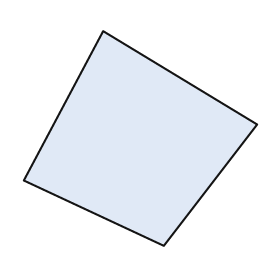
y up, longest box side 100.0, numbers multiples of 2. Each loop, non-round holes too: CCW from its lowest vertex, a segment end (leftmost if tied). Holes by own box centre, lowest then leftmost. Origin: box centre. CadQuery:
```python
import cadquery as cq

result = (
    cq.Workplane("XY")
    .moveTo(10.0, -46.0)
    .lineTo(50.0, 6.0)
    .lineTo(-16.0, 46.0)
    .lineTo(-50.0, -18.0)
    .close()
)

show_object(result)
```